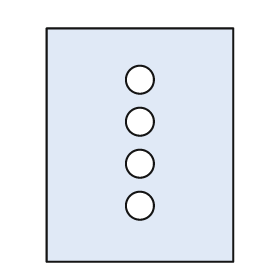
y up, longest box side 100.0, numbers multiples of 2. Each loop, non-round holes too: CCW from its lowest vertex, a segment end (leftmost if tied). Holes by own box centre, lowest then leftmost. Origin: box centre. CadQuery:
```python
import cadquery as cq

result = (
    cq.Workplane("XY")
    .moveTo(-40.0, -50.0)
    .lineTo(40.0, -50.0)
    .lineTo(40.0, 50.0)
    .lineTo(-40.0, 50.0)
    .close()
    .moveTo(0.0, -26.0)
    .circle(6.0)
    .moveTo(0.0, -8.0)
    .circle(6.0)
    .moveTo(0.0, 10.0)
    .circle(6.0)
    .moveTo(0.0, 28.0)
    .circle(6.0)
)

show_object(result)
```